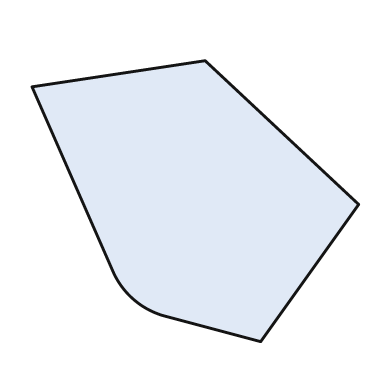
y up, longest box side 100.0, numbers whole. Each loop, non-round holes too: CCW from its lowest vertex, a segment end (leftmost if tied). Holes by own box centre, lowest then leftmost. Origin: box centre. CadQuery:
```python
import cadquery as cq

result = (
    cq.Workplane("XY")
    .moveTo(20.0, -43.0)
    .lineTo(50.0, -1.0)
    .lineTo(3.0, 43.0)
    .lineTo(-50.0, 35.0)
    .lineTo(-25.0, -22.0)
    .threePointArc((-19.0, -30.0), (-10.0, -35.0))
    .close()
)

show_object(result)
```